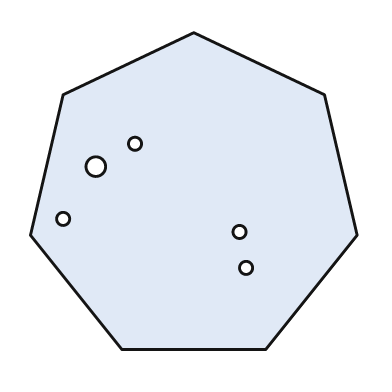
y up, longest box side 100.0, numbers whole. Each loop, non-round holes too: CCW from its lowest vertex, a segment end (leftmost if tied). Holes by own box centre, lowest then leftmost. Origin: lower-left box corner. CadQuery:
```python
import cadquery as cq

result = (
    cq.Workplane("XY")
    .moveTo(28.0, 0.0)
    .lineTo(72.0, 0.0)
    .lineTo(100.0, 35.0)
    .lineTo(90.0, 78.0)
    .lineTo(50.0, 97.0)
    .lineTo(10.0, 78.0)
    .lineTo(0.0, 35.0)
    .close()
    .moveTo(66.0, 25.0)
    .circle(2.0)
    .moveTo(64.0, 36.0)
    .circle(2.0)
    .moveTo(10.0, 40.0)
    .circle(2.0)
    .moveTo(20.0, 56.0)
    .circle(3.0)
    .moveTo(32.0, 63.0)
    .circle(2.0)
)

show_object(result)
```